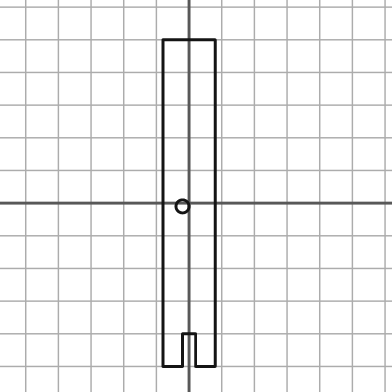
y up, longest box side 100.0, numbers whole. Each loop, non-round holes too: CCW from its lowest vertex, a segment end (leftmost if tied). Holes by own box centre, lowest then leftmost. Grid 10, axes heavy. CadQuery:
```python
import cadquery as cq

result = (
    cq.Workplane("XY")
    .moveTo(-8.0, -50.0)
    .lineTo(-2.0, -50.0)
    .lineTo(-2.0, -40.0)
    .lineTo(2.0, -40.0)
    .lineTo(2.0, -50.0)
    .lineTo(8.0, -50.0)
    .lineTo(8.0, 50.0)
    .lineTo(-8.0, 50.0)
    .close()
    .moveTo(-2.0, -1.0)
    .circle(2.0)
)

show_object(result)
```